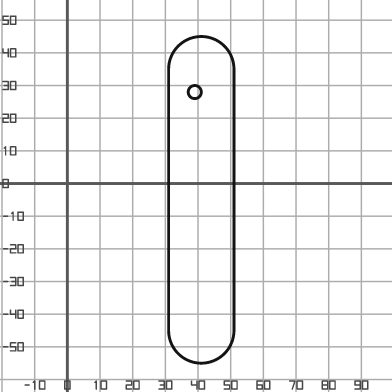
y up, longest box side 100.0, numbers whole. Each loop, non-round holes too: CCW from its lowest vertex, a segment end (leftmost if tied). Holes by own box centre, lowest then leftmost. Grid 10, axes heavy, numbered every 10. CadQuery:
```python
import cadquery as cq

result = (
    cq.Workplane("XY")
    .moveTo(31.0, -45.0)
    .threePointArc((41.0, -55.0), (51.0, -45.0))
    .lineTo(51.0, 35.0)
    .threePointArc((41.0, 45.0), (31.0, 35.0))
    .close()
    .moveTo(39.0, 28.0)
    .circle(2.0)
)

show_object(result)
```